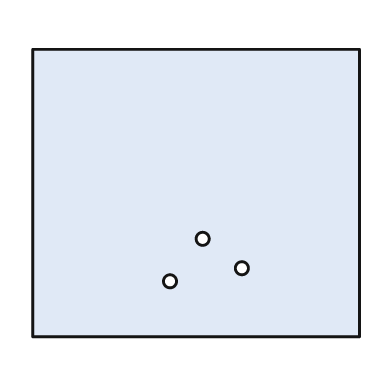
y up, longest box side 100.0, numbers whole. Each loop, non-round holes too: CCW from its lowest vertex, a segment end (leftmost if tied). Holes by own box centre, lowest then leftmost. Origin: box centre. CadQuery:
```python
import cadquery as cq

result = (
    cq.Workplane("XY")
    .moveTo(-50.0, -44.0)
    .lineTo(50.0, -44.0)
    .lineTo(50.0, 44.0)
    .lineTo(-50.0, 44.0)
    .close()
    .moveTo(-8.0, -27.0)
    .circle(2.0)
    .moveTo(14.0, -23.0)
    .circle(2.0)
    .moveTo(2.0, -14.0)
    .circle(2.0)
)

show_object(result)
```